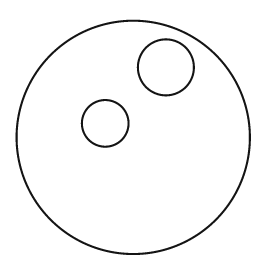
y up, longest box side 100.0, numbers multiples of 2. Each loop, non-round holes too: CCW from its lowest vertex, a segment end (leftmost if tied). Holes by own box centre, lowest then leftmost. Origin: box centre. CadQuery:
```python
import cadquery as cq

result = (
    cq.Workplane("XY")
    .moveTo(0.0, 0.0)
    .circle(50.0)
    .moveTo(-12.0, 6.0)
    .circle(10.0)
    .moveTo(14.0, 30.0)
    .circle(12.0)
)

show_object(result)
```